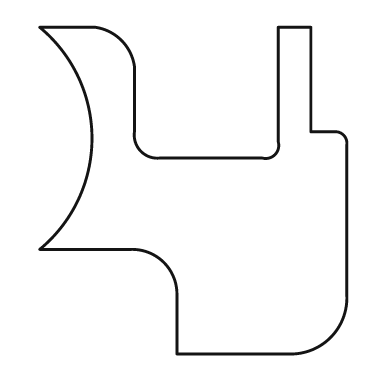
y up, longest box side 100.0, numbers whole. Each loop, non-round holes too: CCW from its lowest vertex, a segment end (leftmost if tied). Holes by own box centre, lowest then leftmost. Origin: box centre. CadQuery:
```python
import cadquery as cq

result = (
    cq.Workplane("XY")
    .moveTo(-5.0, -50.0)
    .lineTo(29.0, -50.0)
    .threePointArc((42.0, -45.0), (47.0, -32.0))
    .lineTo(47.0, 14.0)
    .threePointArc((46.0, 17.0), (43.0, 18.0))
    .lineTo(36.0, 18.0)
    .lineTo(36.0, 50.0)
    .lineTo(26.0, 50.0)
    .lineTo(26.0, 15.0)
    .threePointArc((25.0, 11.0), (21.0, 10.0))
    .lineTo(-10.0, 10.0)
    .threePointArc((-16.0, 12.0), (-18.0, 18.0))
    .lineTo(-18.0, 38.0)
    .threePointArc((-22.0, 46.0), (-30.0, 50.0))
    .lineTo(-47.0, 50.0)
    .threePointArc((-31.0, 16.0), (-47.0, -18.0))
    .lineTo(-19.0, -18.0)
    .threePointArc((-9.0, -22.0), (-5.0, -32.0))
    .close()
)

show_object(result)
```